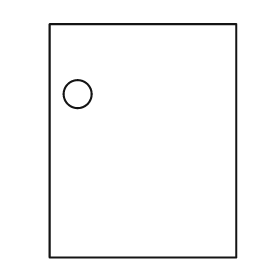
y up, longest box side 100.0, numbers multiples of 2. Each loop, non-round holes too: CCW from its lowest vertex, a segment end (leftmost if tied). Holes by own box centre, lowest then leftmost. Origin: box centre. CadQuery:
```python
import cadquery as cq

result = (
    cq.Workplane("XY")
    .moveTo(-40.0, -50.0)
    .lineTo(40.0, -50.0)
    .lineTo(40.0, 50.0)
    .lineTo(-40.0, 50.0)
    .close()
    .moveTo(-28.0, 20.0)
    .circle(6.0)
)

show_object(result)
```